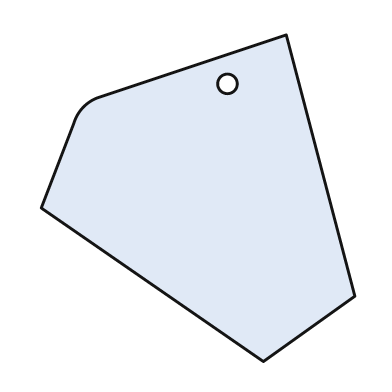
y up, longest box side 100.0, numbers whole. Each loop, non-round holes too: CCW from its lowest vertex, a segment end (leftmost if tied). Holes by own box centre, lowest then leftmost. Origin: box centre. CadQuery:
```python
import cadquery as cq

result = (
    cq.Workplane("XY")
    .moveTo(20.0, -50.0)
    .lineTo(48.0, -30.0)
    .lineTo(27.0, 50.0)
    .lineTo(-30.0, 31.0)
    .threePointArc((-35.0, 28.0), (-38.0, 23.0))
    .lineTo(-48.0, -3.0)
    .close()
    .moveTo(9.0, 35.0)
    .circle(3.0)
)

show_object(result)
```